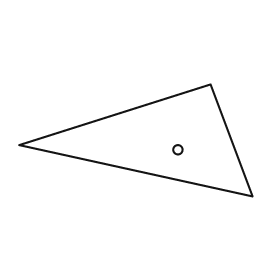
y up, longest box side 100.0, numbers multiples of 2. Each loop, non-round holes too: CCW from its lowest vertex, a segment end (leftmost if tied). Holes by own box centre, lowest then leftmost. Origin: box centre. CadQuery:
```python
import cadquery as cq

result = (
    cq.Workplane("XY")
    .moveTo(50.0, -24.0)
    .lineTo(32.0, 24.0)
    .lineTo(-50.0, -2.0)
    .close()
    .moveTo(18.0, -4.0)
    .circle(2.0)
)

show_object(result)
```